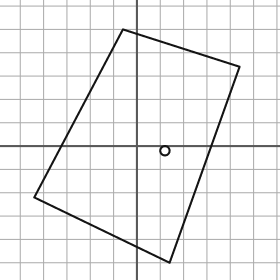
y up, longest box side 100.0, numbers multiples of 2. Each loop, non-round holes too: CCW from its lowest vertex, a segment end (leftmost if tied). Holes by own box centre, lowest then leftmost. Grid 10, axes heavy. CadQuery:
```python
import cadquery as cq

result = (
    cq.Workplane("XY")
    .moveTo(14.0, -50.0)
    .lineTo(44.0, 34.0)
    .lineTo(-6.0, 50.0)
    .lineTo(-44.0, -22.0)
    .close()
    .moveTo(12.0, -2.0)
    .circle(2.0)
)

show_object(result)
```